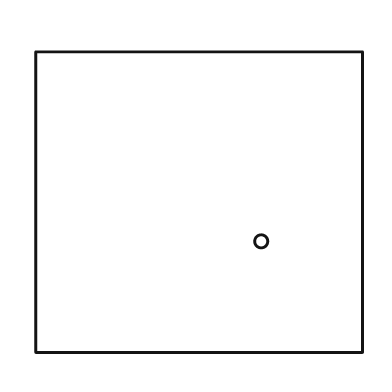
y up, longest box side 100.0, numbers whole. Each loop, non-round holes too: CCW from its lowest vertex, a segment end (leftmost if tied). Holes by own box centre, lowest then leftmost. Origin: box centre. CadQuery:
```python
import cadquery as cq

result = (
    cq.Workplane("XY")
    .moveTo(-50.0, -46.0)
    .lineTo(50.0, -46.0)
    .lineTo(50.0, 46.0)
    .lineTo(-50.0, 46.0)
    .close()
    .moveTo(19.0, -12.0)
    .circle(2.0)
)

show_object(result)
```